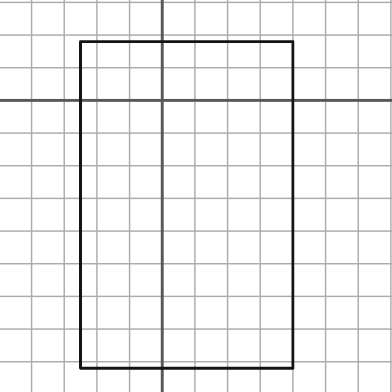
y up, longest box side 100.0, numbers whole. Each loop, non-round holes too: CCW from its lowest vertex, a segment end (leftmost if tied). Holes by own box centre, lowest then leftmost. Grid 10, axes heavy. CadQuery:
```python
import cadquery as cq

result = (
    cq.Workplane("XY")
    .moveTo(-25.0, -82.0)
    .lineTo(40.0, -82.0)
    .lineTo(40.0, 18.0)
    .lineTo(-25.0, 18.0)
    .close()
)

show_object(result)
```